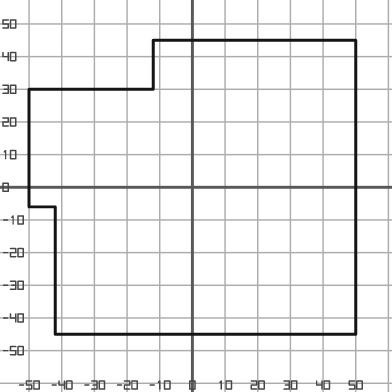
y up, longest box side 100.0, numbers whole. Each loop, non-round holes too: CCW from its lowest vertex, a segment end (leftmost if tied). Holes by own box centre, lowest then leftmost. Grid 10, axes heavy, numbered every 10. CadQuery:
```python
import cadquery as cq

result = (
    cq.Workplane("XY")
    .moveTo(-42.0, -45.0)
    .lineTo(50.0, -45.0)
    .lineTo(50.0, 45.0)
    .lineTo(-12.0, 45.0)
    .lineTo(-12.0, 30.0)
    .lineTo(-50.0, 30.0)
    .lineTo(-50.0, -6.0)
    .lineTo(-42.0, -6.0)
    .close()
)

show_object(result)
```